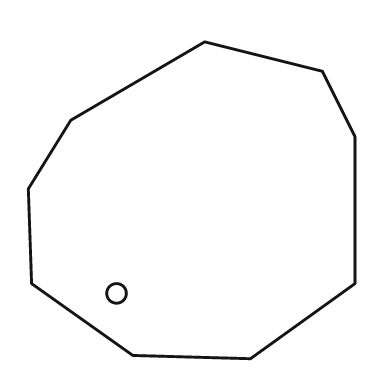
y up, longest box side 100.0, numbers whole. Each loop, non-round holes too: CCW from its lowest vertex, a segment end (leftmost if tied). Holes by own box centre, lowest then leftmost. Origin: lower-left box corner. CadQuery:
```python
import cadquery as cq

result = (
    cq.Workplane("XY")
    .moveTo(68.0, 0.0)
    .lineTo(100.0, 23.0)
    .lineTo(100.0, 68.0)
    .lineTo(90.0, 88.0)
    .lineTo(54.0, 97.0)
    .lineTo(13.0, 73.0)
    .lineTo(0.0, 52.0)
    .lineTo(1.0, 23.0)
    .lineTo(32.0, 1.0)
    .close()
    .moveTo(27.0, 20.0)
    .circle(3.0)
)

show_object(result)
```